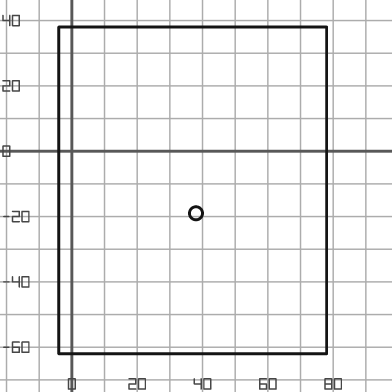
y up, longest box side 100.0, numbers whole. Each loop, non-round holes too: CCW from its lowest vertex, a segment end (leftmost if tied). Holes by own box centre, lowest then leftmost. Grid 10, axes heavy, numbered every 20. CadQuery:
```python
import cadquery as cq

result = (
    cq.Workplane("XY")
    .moveTo(-4.0, -62.0)
    .lineTo(78.0, -62.0)
    .lineTo(78.0, 38.0)
    .lineTo(-4.0, 38.0)
    .close()
    .moveTo(38.0, -19.0)
    .circle(2.0)
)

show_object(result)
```